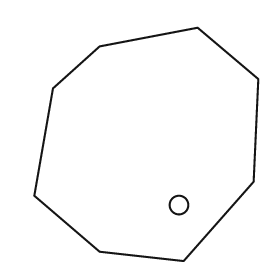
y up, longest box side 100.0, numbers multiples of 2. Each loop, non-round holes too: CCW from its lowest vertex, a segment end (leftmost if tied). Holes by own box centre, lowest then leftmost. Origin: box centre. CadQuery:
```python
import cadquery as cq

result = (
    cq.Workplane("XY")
    .moveTo(16.0, -50.0)
    .lineTo(46.0, -16.0)
    .lineTo(48.0, 28.0)
    .lineTo(22.0, 50.0)
    .lineTo(-20.0, 42.0)
    .lineTo(-40.0, 24.0)
    .lineTo(-48.0, -22.0)
    .lineTo(-20.0, -46.0)
    .close()
    .moveTo(14.0, -26.0)
    .circle(4.0)
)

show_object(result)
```